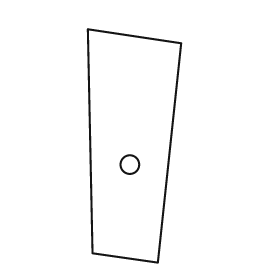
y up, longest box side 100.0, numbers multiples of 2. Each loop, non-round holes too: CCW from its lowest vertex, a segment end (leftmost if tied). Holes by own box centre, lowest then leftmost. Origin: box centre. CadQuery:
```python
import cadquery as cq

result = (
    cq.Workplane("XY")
    .moveTo(10.0, -50.0)
    .lineTo(20.0, 44.0)
    .lineTo(-20.0, 50.0)
    .lineTo(-18.0, -46.0)
    .close()
    .moveTo(-2.0, -8.0)
    .circle(4.0)
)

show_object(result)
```